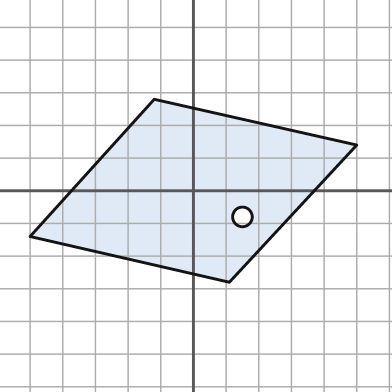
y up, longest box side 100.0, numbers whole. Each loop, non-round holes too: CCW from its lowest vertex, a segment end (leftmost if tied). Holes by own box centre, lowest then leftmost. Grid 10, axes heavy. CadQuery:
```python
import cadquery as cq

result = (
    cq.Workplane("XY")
    .moveTo(11.0, -28.0)
    .lineTo(50.0, 14.0)
    .lineTo(-12.0, 28.0)
    .lineTo(-50.0, -14.0)
    .close()
    .moveTo(15.0, -8.0)
    .circle(3.0)
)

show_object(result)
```